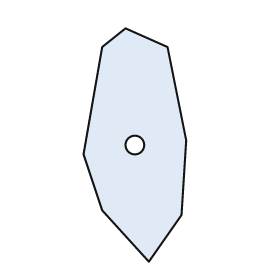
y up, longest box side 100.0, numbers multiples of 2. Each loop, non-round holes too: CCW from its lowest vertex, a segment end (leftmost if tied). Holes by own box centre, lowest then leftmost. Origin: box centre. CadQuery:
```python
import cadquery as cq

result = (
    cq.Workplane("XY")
    .moveTo(6.0, -50.0)
    .lineTo(20.0, -30.0)
    .lineTo(22.0, 2.0)
    .lineTo(14.0, 42.0)
    .lineTo(-4.0, 50.0)
    .lineTo(-14.0, 42.0)
    .lineTo(-22.0, -4.0)
    .lineTo(-14.0, -28.0)
    .close()
    .moveTo(0.0, 0.0)
    .circle(4.0)
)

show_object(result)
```